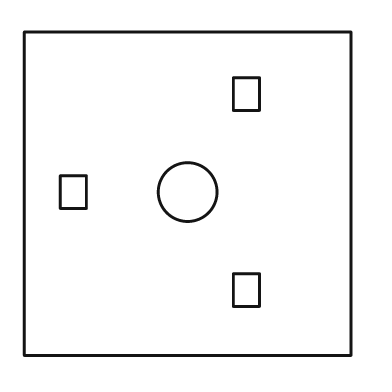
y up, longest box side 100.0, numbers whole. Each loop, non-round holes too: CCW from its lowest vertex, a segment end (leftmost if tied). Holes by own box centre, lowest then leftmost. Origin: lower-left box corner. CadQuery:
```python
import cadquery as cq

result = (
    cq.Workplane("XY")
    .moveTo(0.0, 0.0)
    .lineTo(100.0, 0.0)
    .lineTo(100.0, 99.0)
    .lineTo(0.0, 99.0)
    .close()
    .moveTo(64.0, 15.0)
    .lineTo(72.0, 15.0)
    .lineTo(72.0, 25.0)
    .lineTo(64.0, 25.0)
    .close()
    .moveTo(11.0, 45.0)
    .lineTo(19.0, 45.0)
    .lineTo(19.0, 55.0)
    .lineTo(11.0, 55.0)
    .close()
    .moveTo(50.0, 50.0)
    .circle(9.0)
    .moveTo(64.0, 75.0)
    .lineTo(72.0, 75.0)
    .lineTo(72.0, 85.0)
    .lineTo(64.0, 85.0)
    .close()
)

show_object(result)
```